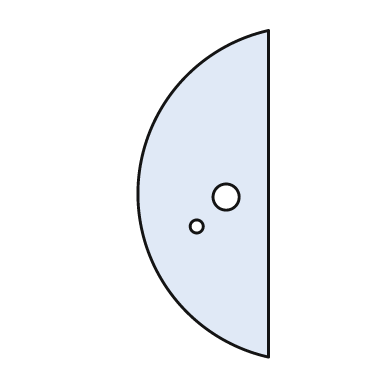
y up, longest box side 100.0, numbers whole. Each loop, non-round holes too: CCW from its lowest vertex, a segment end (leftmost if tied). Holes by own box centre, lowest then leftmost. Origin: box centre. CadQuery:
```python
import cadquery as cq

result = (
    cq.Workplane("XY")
    .moveTo(20.0, -50.0)
    .lineTo(20.0, 50.0)
    .threePointArc((-20.0, 0.0), (20.0, -50.0))
    .close()
    .moveTo(-2.0, -10.0)
    .circle(2.0)
    .moveTo(7.0, -1.0)
    .circle(4.0)
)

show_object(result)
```